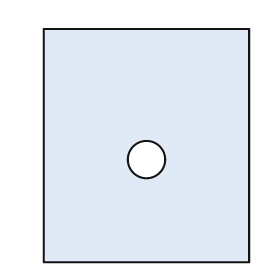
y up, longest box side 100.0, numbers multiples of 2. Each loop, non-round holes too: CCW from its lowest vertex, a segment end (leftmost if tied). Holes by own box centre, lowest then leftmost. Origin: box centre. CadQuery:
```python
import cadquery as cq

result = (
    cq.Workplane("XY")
    .moveTo(-44.0, -50.0)
    .lineTo(44.0, -50.0)
    .lineTo(44.0, 50.0)
    .lineTo(-44.0, 50.0)
    .close()
    .moveTo(0.0, -6.0)
    .circle(8.0)
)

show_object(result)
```